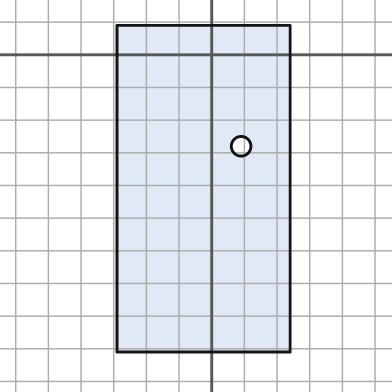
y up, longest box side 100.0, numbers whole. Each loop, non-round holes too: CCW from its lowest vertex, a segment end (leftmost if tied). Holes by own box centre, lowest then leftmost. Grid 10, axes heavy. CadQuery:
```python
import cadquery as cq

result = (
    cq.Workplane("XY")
    .moveTo(-29.0, -91.0)
    .lineTo(24.0, -91.0)
    .lineTo(24.0, 9.0)
    .lineTo(-29.0, 9.0)
    .close()
    .moveTo(9.0, -28.0)
    .circle(3.0)
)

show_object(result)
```